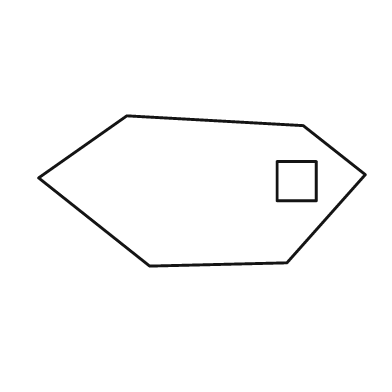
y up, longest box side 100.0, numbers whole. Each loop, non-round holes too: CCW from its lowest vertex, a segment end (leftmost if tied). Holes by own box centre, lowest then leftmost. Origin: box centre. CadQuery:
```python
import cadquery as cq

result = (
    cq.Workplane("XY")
    .moveTo(-16.0, -23.0)
    .lineTo(26.0, -22.0)
    .lineTo(50.0, 5.0)
    .lineTo(31.0, 20.0)
    .lineTo(-23.0, 23.0)
    .lineTo(-50.0, 4.0)
    .close()
    .moveTo(23.0, -3.0)
    .lineTo(35.0, -3.0)
    .lineTo(35.0, 9.0)
    .lineTo(23.0, 9.0)
    .close()
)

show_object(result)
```